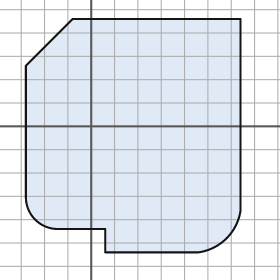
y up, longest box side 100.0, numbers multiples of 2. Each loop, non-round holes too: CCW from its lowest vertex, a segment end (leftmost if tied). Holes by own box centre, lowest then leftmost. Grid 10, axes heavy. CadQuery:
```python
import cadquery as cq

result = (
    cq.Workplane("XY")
    .moveTo(6.0, -54.0)
    .lineTo(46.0, -54.0)
    .threePointArc((58.0, -48.0), (64.0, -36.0))
    .lineTo(64.0, 46.0)
    .lineTo(-8.0, 46.0)
    .lineTo(-28.0, 26.0)
    .lineTo(-28.0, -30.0)
    .threePointArc((-24.0, -40.0), (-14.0, -44.0))
    .lineTo(6.0, -44.0)
    .close()
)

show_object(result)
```